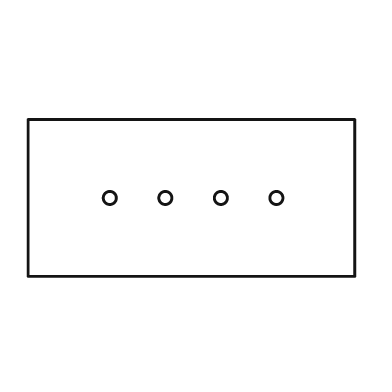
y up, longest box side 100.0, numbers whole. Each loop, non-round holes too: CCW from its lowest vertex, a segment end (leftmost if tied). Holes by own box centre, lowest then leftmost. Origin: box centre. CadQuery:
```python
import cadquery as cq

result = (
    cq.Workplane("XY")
    .moveTo(-50.0, -24.0)
    .lineTo(50.0, -24.0)
    .lineTo(50.0, 24.0)
    .lineTo(-50.0, 24.0)
    .close()
    .moveTo(-25.0, 0.0)
    .circle(2.0)
    .moveTo(-8.0, 0.0)
    .circle(2.0)
    .moveTo(9.0, 0.0)
    .circle(2.0)
    .moveTo(26.0, 0.0)
    .circle(2.0)
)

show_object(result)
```